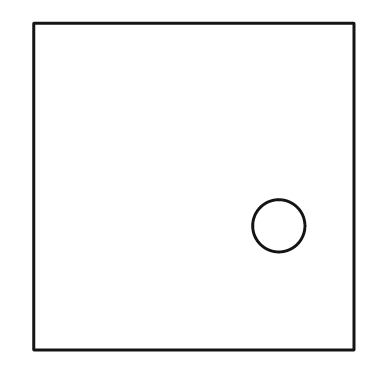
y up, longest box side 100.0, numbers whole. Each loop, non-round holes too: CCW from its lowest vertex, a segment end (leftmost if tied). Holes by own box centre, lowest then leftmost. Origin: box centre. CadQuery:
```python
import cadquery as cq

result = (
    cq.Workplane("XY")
    .moveTo(-49.0, -50.0)
    .lineTo(49.0, -50.0)
    .lineTo(49.0, 50.0)
    .lineTo(-49.0, 50.0)
    .close()
    .moveTo(26.0, -12.0)
    .circle(8.0)
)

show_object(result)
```